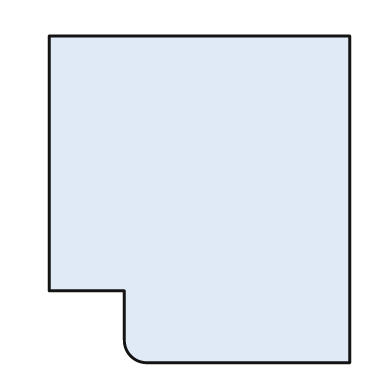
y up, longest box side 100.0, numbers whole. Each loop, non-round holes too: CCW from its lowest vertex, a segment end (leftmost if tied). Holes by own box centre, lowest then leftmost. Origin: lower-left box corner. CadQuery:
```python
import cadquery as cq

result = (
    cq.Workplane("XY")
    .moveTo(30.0, 0.0)
    .lineTo(92.0, 0.0)
    .lineTo(92.0, 100.0)
    .lineTo(0.0, 100.0)
    .lineTo(0.0, 22.0)
    .lineTo(23.0, 22.0)
    .lineTo(23.0, 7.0)
    .threePointArc((25.0, 2.0), (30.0, 0.0))
    .close()
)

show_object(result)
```